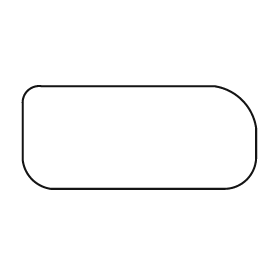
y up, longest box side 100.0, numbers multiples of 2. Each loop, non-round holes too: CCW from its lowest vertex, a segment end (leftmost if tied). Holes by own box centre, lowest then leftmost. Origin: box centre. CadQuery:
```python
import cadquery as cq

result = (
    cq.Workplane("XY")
    .moveTo(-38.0, -22.0)
    .lineTo(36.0, -22.0)
    .threePointArc((46.0, -18.0), (50.0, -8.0))
    .lineTo(50.0, 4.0)
    .threePointArc((44.0, 16.0), (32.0, 22.0))
    .lineTo(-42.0, 22.0)
    .threePointArc((-48.0, 20.0), (-50.0, 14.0))
    .lineTo(-50.0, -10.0)
    .threePointArc((-46.0, -18.0), (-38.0, -22.0))
    .close()
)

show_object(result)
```